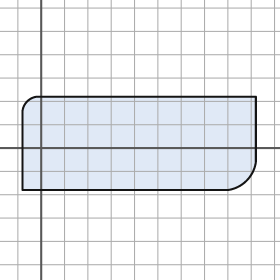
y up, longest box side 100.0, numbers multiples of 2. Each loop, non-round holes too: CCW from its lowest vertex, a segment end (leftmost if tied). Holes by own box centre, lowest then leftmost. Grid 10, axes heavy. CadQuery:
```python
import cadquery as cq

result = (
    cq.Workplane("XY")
    .moveTo(-8.0, -18.0)
    .lineTo(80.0, -18.0)
    .threePointArc((88.0, -14.0), (92.0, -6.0))
    .lineTo(92.0, 22.0)
    .lineTo(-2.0, 22.0)
    .threePointArc((-6.0, 20.0), (-8.0, 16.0))
    .close()
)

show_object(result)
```